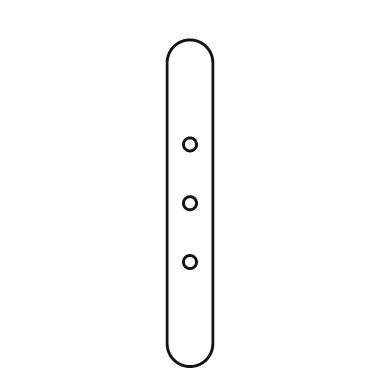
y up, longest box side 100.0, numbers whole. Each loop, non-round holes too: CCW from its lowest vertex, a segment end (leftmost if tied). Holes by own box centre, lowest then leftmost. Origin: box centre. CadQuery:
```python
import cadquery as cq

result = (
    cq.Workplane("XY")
    .moveTo(-7.0, -43.0)
    .threePointArc((0.0, -50.0), (7.0, -43.0))
    .lineTo(7.0, 43.0)
    .threePointArc((0.0, 50.0), (-7.0, 43.0))
    .close()
    .moveTo(0.0, -18.0)
    .circle(2.0)
    .moveTo(0.0, 0.0)
    .circle(2.0)
    .moveTo(0.0, 18.0)
    .circle(2.0)
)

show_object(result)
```